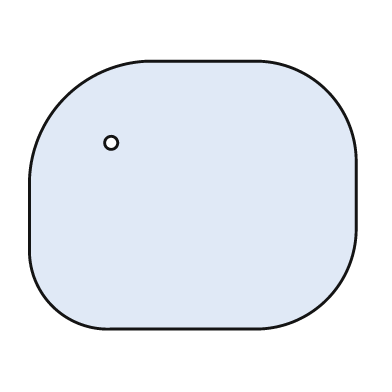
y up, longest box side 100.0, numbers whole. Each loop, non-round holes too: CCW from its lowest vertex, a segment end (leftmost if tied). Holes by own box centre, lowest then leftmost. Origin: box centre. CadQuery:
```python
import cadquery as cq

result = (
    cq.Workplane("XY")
    .moveTo(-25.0, -41.0)
    .lineTo(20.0, -41.0)
    .threePointArc((41.0, -32.0), (50.0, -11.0))
    .lineTo(50.0, 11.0)
    .threePointArc((41.0, 32.0), (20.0, 41.0))
    .lineTo(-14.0, 41.0)
    .threePointArc((-39.0, 30.0), (-50.0, 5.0))
    .lineTo(-50.0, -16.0)
    .threePointArc((-43.0, -34.0), (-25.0, -41.0))
    .close()
    .moveTo(-25.0, 16.0)
    .circle(2.0)
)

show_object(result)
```